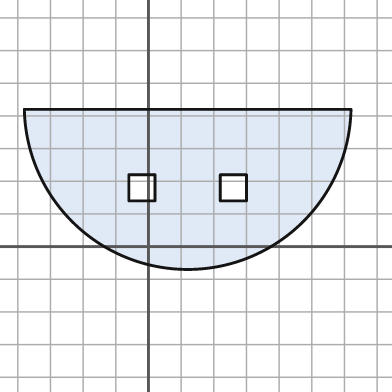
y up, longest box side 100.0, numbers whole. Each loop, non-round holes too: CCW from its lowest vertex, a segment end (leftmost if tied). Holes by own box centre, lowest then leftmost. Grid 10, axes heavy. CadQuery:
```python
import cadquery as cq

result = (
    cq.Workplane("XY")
    .moveTo(-38.0, 42.0)
    .threePointArc((12.0, -7.0), (62.0, 42.0))
    .close()
    .moveTo(-6.0, 14.0)
    .lineTo(2.0, 14.0)
    .lineTo(2.0, 22.0)
    .lineTo(-6.0, 22.0)
    .close()
    .moveTo(22.0, 14.0)
    .lineTo(30.0, 14.0)
    .lineTo(30.0, 22.0)
    .lineTo(22.0, 22.0)
    .close()
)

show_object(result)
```